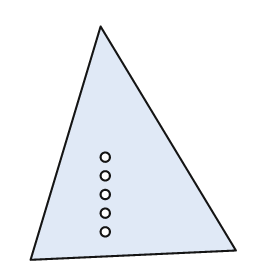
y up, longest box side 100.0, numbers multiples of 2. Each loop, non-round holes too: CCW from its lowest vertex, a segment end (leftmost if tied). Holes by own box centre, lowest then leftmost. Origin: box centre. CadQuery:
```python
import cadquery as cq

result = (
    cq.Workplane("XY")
    .moveTo(-44.0, -50.0)
    .lineTo(44.0, -46.0)
    .lineTo(-14.0, 50.0)
    .close()
    .moveTo(-12.0, -38.0)
    .circle(2.0)
    .moveTo(-12.0, -30.0)
    .circle(2.0)
    .moveTo(-12.0, -22.0)
    .circle(2.0)
    .moveTo(-12.0, -14.0)
    .circle(2.0)
    .moveTo(-12.0, -6.0)
    .circle(2.0)
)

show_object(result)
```